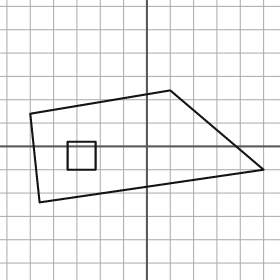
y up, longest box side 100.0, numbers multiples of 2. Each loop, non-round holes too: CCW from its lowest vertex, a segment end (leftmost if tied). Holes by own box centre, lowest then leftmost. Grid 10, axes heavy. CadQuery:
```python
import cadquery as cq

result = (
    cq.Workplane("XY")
    .moveTo(-46.0, -24.0)
    .lineTo(50.0, -10.0)
    .lineTo(10.0, 24.0)
    .lineTo(-50.0, 14.0)
    .close()
    .moveTo(-34.0, -10.0)
    .lineTo(-22.0, -10.0)
    .lineTo(-22.0, 2.0)
    .lineTo(-34.0, 2.0)
    .close()
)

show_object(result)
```